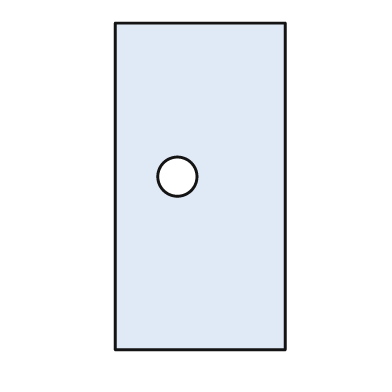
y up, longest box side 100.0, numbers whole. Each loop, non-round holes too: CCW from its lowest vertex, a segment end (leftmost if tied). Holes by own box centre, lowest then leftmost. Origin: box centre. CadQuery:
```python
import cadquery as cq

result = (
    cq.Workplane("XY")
    .moveTo(-26.0, -50.0)
    .lineTo(26.0, -50.0)
    .lineTo(26.0, 50.0)
    .lineTo(-26.0, 50.0)
    .close()
    .moveTo(-7.0, 3.0)
    .circle(6.0)
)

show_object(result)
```